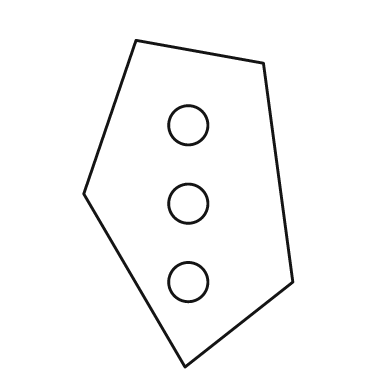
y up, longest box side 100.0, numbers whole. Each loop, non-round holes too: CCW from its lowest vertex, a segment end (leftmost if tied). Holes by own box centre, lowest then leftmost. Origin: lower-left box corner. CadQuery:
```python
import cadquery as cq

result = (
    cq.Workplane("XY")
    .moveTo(31.0, 0.0)
    .lineTo(64.0, 26.0)
    .lineTo(55.0, 93.0)
    .lineTo(16.0, 100.0)
    .lineTo(0.0, 53.0)
    .close()
    .moveTo(32.0, 26.0)
    .circle(6.0)
    .moveTo(32.0, 50.0)
    .circle(6.0)
    .moveTo(32.0, 74.0)
    .circle(6.0)
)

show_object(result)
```